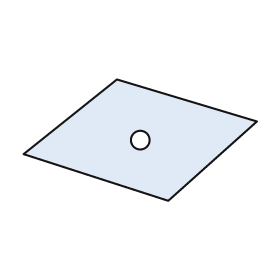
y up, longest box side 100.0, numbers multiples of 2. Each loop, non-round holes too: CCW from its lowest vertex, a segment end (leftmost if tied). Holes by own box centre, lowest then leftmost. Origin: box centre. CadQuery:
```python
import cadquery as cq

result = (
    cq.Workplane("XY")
    .moveTo(12.0, -26.0)
    .lineTo(50.0, 8.0)
    .lineTo(-10.0, 26.0)
    .lineTo(-50.0, -6.0)
    .close()
    .moveTo(0.0, 0.0)
    .circle(4.0)
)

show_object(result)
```